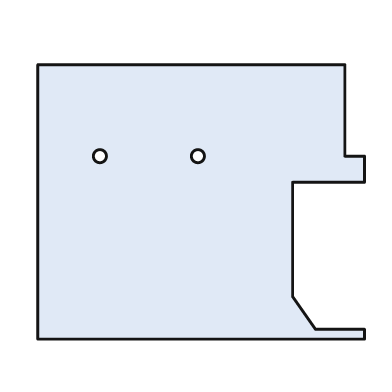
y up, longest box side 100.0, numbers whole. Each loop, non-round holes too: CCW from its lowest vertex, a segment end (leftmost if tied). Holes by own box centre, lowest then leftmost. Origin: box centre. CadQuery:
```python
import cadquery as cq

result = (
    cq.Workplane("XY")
    .moveTo(-50.0, -42.0)
    .lineTo(50.0, -42.0)
    .lineTo(50.0, -39.0)
    .lineTo(35.0, -39.0)
    .lineTo(28.0, -29.0)
    .lineTo(28.0, 6.0)
    .lineTo(50.0, 6.0)
    .lineTo(50.0, 14.0)
    .lineTo(44.0, 14.0)
    .lineTo(44.0, 42.0)
    .lineTo(-50.0, 42.0)
    .close()
    .moveTo(-31.0, 14.0)
    .circle(2.0)
    .moveTo(-1.0, 14.0)
    .circle(2.0)
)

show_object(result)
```